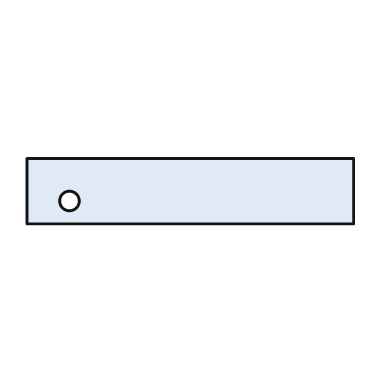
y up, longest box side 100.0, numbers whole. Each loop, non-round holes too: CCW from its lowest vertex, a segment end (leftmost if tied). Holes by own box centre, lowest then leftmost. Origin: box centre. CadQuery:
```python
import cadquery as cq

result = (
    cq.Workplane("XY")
    .moveTo(-50.0, -10.0)
    .lineTo(50.0, -10.0)
    .lineTo(50.0, 10.0)
    .lineTo(-50.0, 10.0)
    .close()
    .moveTo(-37.0, -3.0)
    .circle(3.0)
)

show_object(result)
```